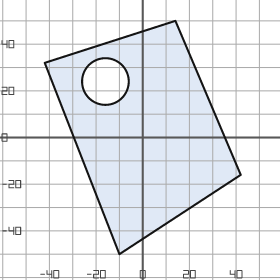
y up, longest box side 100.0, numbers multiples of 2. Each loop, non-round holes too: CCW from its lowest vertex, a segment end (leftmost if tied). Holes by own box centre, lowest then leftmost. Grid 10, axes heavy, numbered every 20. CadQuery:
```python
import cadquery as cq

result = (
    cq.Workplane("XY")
    .moveTo(-10.0, -50.0)
    .lineTo(42.0, -16.0)
    .lineTo(14.0, 50.0)
    .lineTo(-42.0, 32.0)
    .close()
    .moveTo(-16.0, 24.0)
    .circle(10.0)
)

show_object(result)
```